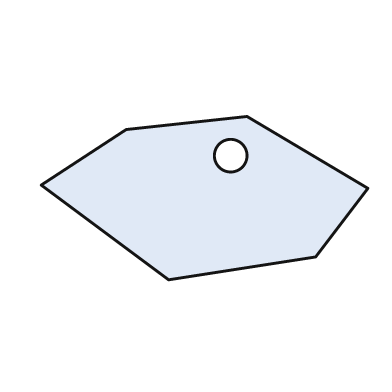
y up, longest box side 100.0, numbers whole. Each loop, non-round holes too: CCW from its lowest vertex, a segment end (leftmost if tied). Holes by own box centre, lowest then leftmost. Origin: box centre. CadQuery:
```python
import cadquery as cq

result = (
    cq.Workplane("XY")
    .moveTo(-11.0, -25.0)
    .lineTo(34.0, -18.0)
    .lineTo(50.0, 3.0)
    .lineTo(13.0, 25.0)
    .lineTo(-24.0, 21.0)
    .lineTo(-50.0, 4.0)
    .close()
    .moveTo(8.0, 13.0)
    .circle(5.0)
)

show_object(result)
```